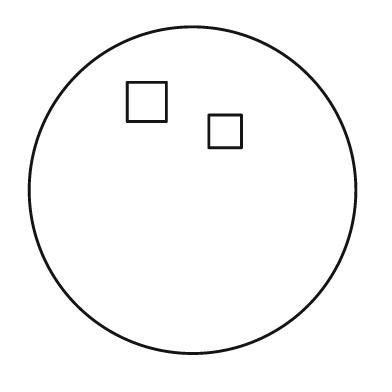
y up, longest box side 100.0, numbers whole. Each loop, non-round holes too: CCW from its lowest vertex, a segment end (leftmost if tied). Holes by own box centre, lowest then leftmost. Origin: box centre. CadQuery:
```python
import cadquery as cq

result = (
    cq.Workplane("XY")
    .moveTo(0.0, 0.0)
    .circle(50.0)
    .moveTo(5.0, 13.0)
    .lineTo(15.0, 13.0)
    .lineTo(15.0, 23.0)
    .lineTo(5.0, 23.0)
    .close()
    .moveTo(-20.0, 21.0)
    .lineTo(-8.0, 21.0)
    .lineTo(-8.0, 33.0)
    .lineTo(-20.0, 33.0)
    .close()
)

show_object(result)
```